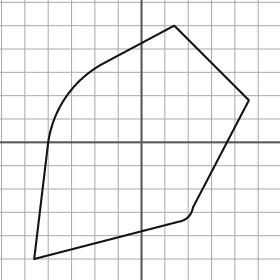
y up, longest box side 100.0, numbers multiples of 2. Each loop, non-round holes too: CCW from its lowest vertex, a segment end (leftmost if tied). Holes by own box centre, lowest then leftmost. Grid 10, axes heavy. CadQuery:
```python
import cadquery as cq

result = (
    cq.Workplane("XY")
    .moveTo(-46.0, -50.0)
    .lineTo(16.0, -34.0)
    .threePointArc((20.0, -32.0), (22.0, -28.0))
    .lineTo(46.0, 18.0)
    .lineTo(14.0, 50.0)
    .lineTo(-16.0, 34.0)
    .threePointArc((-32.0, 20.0), (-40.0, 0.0))
    .close()
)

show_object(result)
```